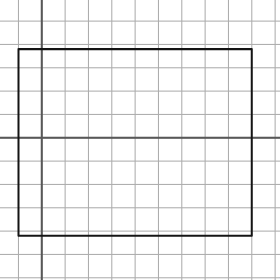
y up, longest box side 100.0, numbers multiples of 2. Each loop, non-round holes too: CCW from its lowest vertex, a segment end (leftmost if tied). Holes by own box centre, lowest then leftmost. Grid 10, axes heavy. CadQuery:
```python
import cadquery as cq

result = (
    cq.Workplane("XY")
    .moveTo(-10.0, -42.0)
    .lineTo(90.0, -42.0)
    .lineTo(90.0, 38.0)
    .lineTo(-10.0, 38.0)
    .close()
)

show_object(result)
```